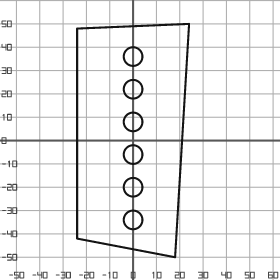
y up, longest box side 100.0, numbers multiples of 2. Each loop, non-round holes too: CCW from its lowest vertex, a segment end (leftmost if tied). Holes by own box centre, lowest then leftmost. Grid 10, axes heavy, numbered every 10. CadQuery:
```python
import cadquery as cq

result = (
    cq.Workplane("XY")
    .moveTo(18.0, -50.0)
    .lineTo(24.0, 50.0)
    .lineTo(-24.0, 48.0)
    .lineTo(-24.0, -42.0)
    .close()
    .moveTo(0.0, -34.0)
    .circle(4.0)
    .moveTo(0.0, -20.0)
    .circle(4.0)
    .moveTo(0.0, -6.0)
    .circle(4.0)
    .moveTo(0.0, 8.0)
    .circle(4.0)
    .moveTo(0.0, 22.0)
    .circle(4.0)
    .moveTo(0.0, 36.0)
    .circle(4.0)
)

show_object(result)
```